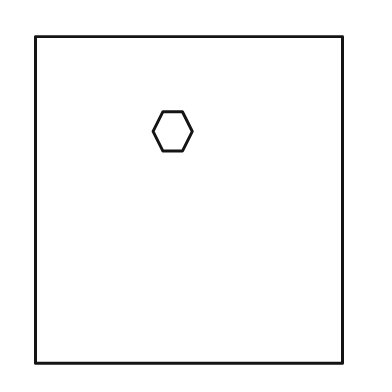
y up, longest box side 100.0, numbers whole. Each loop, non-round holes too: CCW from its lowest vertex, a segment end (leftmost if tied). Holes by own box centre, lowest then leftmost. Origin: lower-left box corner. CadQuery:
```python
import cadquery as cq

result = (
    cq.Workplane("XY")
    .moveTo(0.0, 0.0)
    .lineTo(94.0, 0.0)
    .lineTo(94.0, 100.0)
    .lineTo(0.0, 100.0)
    .close()
    .moveTo(39.0, 65.0)
    .lineTo(45.0, 65.0)
    .lineTo(48.0, 71.0)
    .lineTo(45.0, 77.0)
    .lineTo(39.0, 77.0)
    .lineTo(36.0, 71.0)
    .close()
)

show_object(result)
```